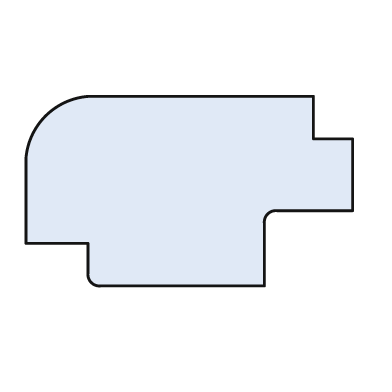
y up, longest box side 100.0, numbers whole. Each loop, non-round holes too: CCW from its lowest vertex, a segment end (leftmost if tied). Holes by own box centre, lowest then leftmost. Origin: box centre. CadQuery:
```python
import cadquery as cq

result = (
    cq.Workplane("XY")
    .moveTo(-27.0, -29.0)
    .lineTo(23.0, -29.0)
    .lineTo(23.0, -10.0)
    .threePointArc((24.0, -7.0), (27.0, -6.0))
    .lineTo(50.0, -6.0)
    .lineTo(50.0, 16.0)
    .lineTo(38.0, 16.0)
    .lineTo(38.0, 29.0)
    .lineTo(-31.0, 29.0)
    .threePointArc((-44.0, 23.0), (-50.0, 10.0))
    .lineTo(-50.0, -16.0)
    .lineTo(-31.0, -16.0)
    .lineTo(-31.0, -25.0)
    .threePointArc((-30.0, -28.0), (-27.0, -29.0))
    .close()
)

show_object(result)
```